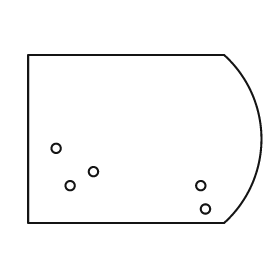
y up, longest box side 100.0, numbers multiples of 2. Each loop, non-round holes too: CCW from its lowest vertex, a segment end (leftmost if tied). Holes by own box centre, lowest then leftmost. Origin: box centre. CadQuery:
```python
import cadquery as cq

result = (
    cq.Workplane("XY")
    .moveTo(-50.0, -36.0)
    .lineTo(34.0, -36.0)
    .threePointArc((50.0, 0.0), (34.0, 36.0))
    .lineTo(-50.0, 36.0)
    .close()
    .moveTo(26.0, -30.0)
    .circle(2.0)
    .moveTo(-32.0, -20.0)
    .circle(2.0)
    .moveTo(24.0, -20.0)
    .circle(2.0)
    .moveTo(-22.0, -14.0)
    .circle(2.0)
    .moveTo(-38.0, -4.0)
    .circle(2.0)
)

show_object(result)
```